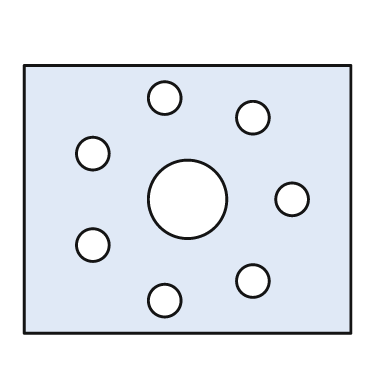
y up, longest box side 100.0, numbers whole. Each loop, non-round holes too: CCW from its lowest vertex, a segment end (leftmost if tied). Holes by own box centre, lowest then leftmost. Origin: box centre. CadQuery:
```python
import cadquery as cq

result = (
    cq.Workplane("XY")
    .moveTo(-50.0, -41.0)
    .lineTo(50.0, -41.0)
    .lineTo(50.0, 41.0)
    .lineTo(-50.0, 41.0)
    .close()
    .moveTo(-7.0, -31.0)
    .circle(5.0)
    .moveTo(20.0, -25.0)
    .circle(5.0)
    .moveTo(-29.0, -14.0)
    .circle(5.0)
    .moveTo(0.0, 0.0)
    .circle(12.0)
    .moveTo(32.0, 0.0)
    .circle(5.0)
    .moveTo(-29.0, 14.0)
    .circle(5.0)
    .moveTo(20.0, 25.0)
    .circle(5.0)
    .moveTo(-7.0, 31.0)
    .circle(5.0)
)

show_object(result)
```